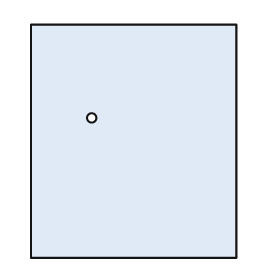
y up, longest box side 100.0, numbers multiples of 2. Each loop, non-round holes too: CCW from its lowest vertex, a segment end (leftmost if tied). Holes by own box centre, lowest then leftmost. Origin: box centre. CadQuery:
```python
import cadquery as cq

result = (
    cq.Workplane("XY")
    .moveTo(-44.0, -50.0)
    .lineTo(44.0, -50.0)
    .lineTo(44.0, 50.0)
    .lineTo(-44.0, 50.0)
    .close()
    .moveTo(-18.0, 10.0)
    .circle(2.0)
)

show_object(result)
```